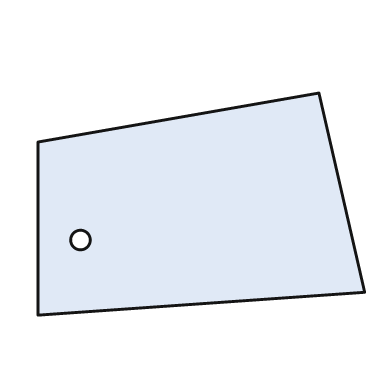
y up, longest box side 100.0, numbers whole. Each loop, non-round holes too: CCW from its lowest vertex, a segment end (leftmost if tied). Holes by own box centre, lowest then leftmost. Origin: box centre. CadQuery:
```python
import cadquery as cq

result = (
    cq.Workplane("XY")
    .moveTo(-50.0, -34.0)
    .lineTo(50.0, -27.0)
    .lineTo(36.0, 34.0)
    .lineTo(-50.0, 19.0)
    .close()
    .moveTo(-37.0, -11.0)
    .circle(3.0)
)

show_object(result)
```